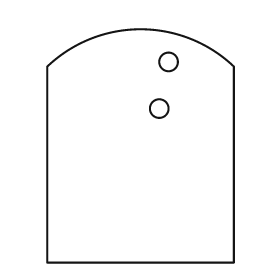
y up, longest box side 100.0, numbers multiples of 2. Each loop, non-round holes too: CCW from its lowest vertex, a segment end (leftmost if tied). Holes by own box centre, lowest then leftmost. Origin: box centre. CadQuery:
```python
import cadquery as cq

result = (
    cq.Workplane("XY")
    .moveTo(-40.0, -50.0)
    .lineTo(40.0, -50.0)
    .lineTo(40.0, 34.0)
    .threePointArc((0.0, 50.0), (-40.0, 34.0))
    .close()
    .moveTo(8.0, 16.0)
    .circle(4.0)
    .moveTo(12.0, 36.0)
    .circle(4.0)
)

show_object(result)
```